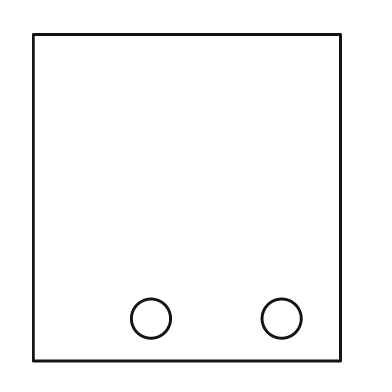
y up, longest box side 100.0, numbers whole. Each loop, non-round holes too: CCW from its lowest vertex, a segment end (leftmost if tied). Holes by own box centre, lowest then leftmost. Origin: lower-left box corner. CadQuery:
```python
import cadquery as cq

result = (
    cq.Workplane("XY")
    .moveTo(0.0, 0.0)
    .lineTo(94.0, 0.0)
    .lineTo(94.0, 100.0)
    .lineTo(0.0, 100.0)
    .close()
    .moveTo(36.0, 13.0)
    .circle(6.0)
    .moveTo(76.0, 13.0)
    .circle(6.0)
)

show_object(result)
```